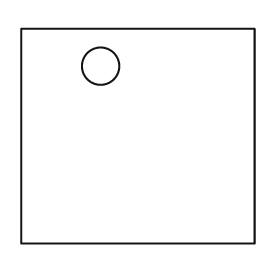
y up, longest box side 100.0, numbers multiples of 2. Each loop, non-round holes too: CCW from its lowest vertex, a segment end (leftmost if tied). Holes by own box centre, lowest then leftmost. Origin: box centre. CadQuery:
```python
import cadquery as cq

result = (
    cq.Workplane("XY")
    .moveTo(-50.0, -46.0)
    .lineTo(50.0, -46.0)
    .lineTo(50.0, 46.0)
    .lineTo(-50.0, 46.0)
    .close()
    .moveTo(-16.0, 30.0)
    .circle(8.0)
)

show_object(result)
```